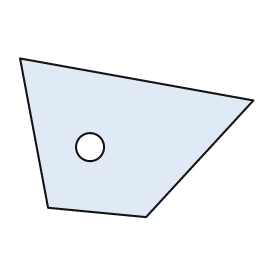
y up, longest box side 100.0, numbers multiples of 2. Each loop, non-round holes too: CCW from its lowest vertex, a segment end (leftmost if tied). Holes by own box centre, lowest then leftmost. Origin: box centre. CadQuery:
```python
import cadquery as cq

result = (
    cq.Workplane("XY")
    .moveTo(4.0, -34.0)
    .lineTo(50.0, 16.0)
    .lineTo(-50.0, 34.0)
    .lineTo(-38.0, -30.0)
    .close()
    .moveTo(-20.0, -4.0)
    .circle(6.0)
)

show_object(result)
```